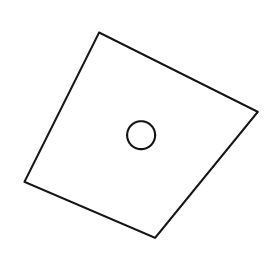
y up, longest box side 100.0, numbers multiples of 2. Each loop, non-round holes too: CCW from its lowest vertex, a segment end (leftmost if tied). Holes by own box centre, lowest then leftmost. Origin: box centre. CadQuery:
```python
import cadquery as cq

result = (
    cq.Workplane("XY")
    .moveTo(6.0, -44.0)
    .lineTo(50.0, 10.0)
    .lineTo(-18.0, 44.0)
    .lineTo(-50.0, -20.0)
    .close()
    .moveTo(0.0, 0.0)
    .circle(6.0)
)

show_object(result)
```